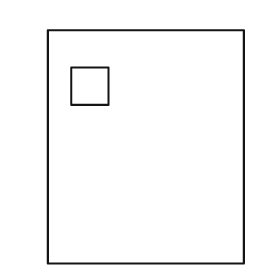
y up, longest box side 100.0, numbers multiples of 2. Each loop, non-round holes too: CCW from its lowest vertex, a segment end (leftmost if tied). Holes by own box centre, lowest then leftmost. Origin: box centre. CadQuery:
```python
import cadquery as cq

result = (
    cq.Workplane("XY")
    .moveTo(-42.0, -50.0)
    .lineTo(42.0, -50.0)
    .lineTo(42.0, 50.0)
    .lineTo(-42.0, 50.0)
    .close()
    .moveTo(-32.0, 18.0)
    .lineTo(-16.0, 18.0)
    .lineTo(-16.0, 34.0)
    .lineTo(-32.0, 34.0)
    .close()
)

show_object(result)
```